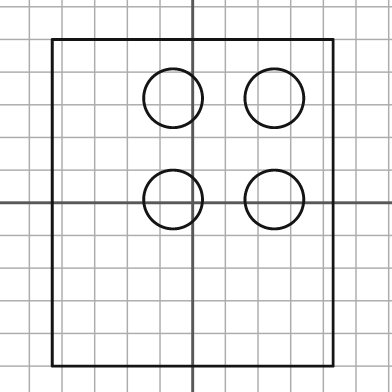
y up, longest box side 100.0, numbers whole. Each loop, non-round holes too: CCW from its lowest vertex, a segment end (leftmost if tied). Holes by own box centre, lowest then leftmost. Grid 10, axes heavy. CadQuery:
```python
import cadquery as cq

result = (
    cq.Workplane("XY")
    .moveTo(-43.0, -50.0)
    .lineTo(43.0, -50.0)
    .lineTo(43.0, 50.0)
    .lineTo(-43.0, 50.0)
    .close()
    .moveTo(-6.0, 1.0)
    .circle(9.0)
    .moveTo(25.0, 1.0)
    .circle(9.0)
    .moveTo(-6.0, 32.0)
    .circle(9.0)
    .moveTo(25.0, 32.0)
    .circle(9.0)
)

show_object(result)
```